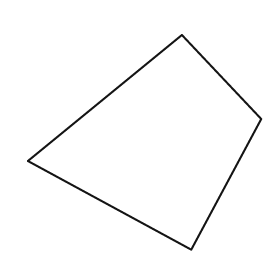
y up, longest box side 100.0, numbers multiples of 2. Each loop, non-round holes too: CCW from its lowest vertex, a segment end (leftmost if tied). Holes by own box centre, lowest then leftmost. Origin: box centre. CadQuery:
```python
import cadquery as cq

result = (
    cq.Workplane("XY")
    .moveTo(20.0, -46.0)
    .lineTo(50.0, 10.0)
    .lineTo(16.0, 46.0)
    .lineTo(-50.0, -8.0)
    .close()
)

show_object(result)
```